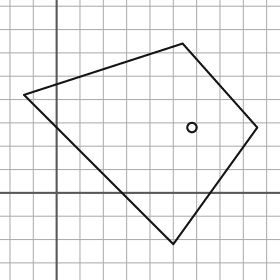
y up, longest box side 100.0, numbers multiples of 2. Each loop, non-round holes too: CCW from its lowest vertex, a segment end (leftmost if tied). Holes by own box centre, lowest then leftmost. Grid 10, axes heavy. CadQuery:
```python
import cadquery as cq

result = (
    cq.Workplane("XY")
    .moveTo(50.0, -22.0)
    .lineTo(86.0, 28.0)
    .lineTo(54.0, 64.0)
    .lineTo(-14.0, 42.0)
    .close()
    .moveTo(58.0, 28.0)
    .circle(2.0)
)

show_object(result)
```